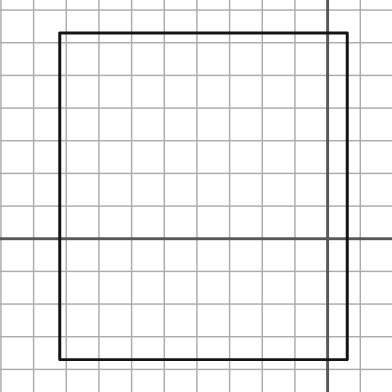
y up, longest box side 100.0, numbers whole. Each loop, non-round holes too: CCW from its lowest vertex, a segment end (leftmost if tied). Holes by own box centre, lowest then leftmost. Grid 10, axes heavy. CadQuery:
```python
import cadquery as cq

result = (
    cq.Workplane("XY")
    .moveTo(-82.0, -37.0)
    .lineTo(6.0, -37.0)
    .lineTo(6.0, 63.0)
    .lineTo(-82.0, 63.0)
    .close()
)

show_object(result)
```